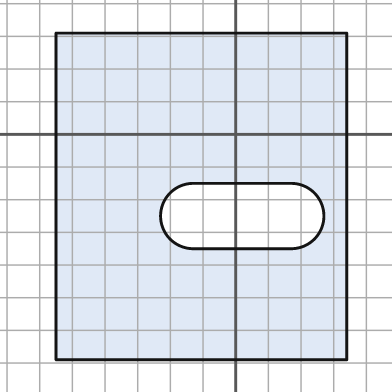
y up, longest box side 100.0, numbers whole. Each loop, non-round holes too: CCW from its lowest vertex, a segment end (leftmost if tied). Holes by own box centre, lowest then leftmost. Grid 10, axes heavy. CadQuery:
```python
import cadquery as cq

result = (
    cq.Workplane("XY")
    .moveTo(-55.0, -69.0)
    .lineTo(34.0, -69.0)
    .lineTo(34.0, 31.0)
    .lineTo(-55.0, 31.0)
    .close()
    .moveTo(-13.0, -35.0)
    .lineTo(17.0, -35.0)
    .threePointArc((27.0, -25.0), (17.0, -15.0))
    .lineTo(-13.0, -15.0)
    .threePointArc((-23.0, -25.0), (-13.0, -35.0))
    .close()
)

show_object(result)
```